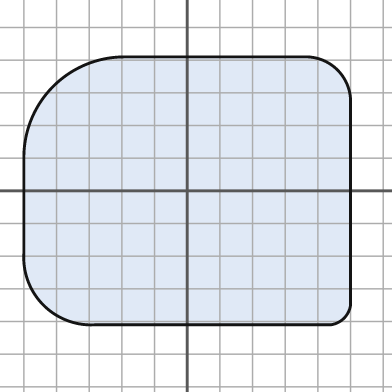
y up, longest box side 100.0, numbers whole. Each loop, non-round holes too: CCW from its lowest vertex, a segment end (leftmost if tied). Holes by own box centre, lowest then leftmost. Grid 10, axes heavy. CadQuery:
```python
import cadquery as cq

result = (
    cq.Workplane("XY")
    .moveTo(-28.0, -41.0)
    .lineTo(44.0, -41.0)
    .threePointArc((48.0, -39.0), (50.0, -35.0))
    .lineTo(50.0, 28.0)
    .threePointArc((46.0, 37.0), (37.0, 41.0))
    .lineTo(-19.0, 41.0)
    .threePointArc((-41.0, 32.0), (-50.0, 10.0))
    .lineTo(-50.0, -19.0)
    .threePointArc((-44.0, -35.0), (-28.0, -41.0))
    .close()
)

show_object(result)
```